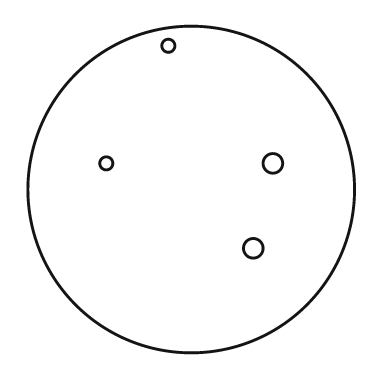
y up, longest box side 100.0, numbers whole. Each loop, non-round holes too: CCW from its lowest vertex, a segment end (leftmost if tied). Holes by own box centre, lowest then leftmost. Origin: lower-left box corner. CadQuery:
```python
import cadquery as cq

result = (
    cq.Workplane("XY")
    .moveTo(50.0, 50.0)
    .circle(50.0)
    .moveTo(69.0, 32.0)
    .circle(3.0)
    .moveTo(24.0, 58.0)
    .circle(2.0)
    .moveTo(75.0, 58.0)
    .circle(3.0)
    .moveTo(43.0, 94.0)
    .circle(2.0)
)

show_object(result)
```